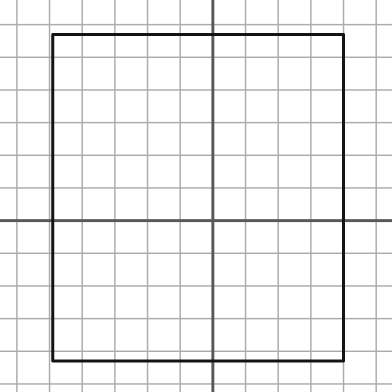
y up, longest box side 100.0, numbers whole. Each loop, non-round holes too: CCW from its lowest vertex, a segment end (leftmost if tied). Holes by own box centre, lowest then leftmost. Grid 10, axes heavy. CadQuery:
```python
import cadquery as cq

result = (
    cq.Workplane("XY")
    .moveTo(-49.0, -43.0)
    .lineTo(40.0, -43.0)
    .lineTo(40.0, 57.0)
    .lineTo(-49.0, 57.0)
    .close()
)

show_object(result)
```